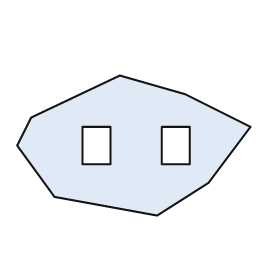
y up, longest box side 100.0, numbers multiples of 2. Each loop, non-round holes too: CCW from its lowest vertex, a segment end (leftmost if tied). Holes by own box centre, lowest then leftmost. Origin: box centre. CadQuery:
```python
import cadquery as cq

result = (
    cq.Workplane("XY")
    .moveTo(10.0, -30.0)
    .lineTo(32.0, -16.0)
    .lineTo(50.0, 8.0)
    .lineTo(22.0, 22.0)
    .lineTo(-6.0, 30.0)
    .lineTo(-44.0, 12.0)
    .lineTo(-50.0, 0.0)
    .lineTo(-34.0, -22.0)
    .close()
    .moveTo(-22.0, -8.0)
    .lineTo(-10.0, -8.0)
    .lineTo(-10.0, 8.0)
    .lineTo(-22.0, 8.0)
    .close()
    .moveTo(12.0, -8.0)
    .lineTo(24.0, -8.0)
    .lineTo(24.0, 8.0)
    .lineTo(12.0, 8.0)
    .close()
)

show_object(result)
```